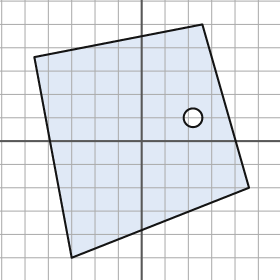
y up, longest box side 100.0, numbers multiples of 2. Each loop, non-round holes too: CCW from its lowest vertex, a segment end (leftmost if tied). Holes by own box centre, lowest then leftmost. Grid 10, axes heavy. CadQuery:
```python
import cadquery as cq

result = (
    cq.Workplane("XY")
    .moveTo(-30.0, -50.0)
    .lineTo(46.0, -20.0)
    .lineTo(26.0, 50.0)
    .lineTo(-46.0, 36.0)
    .close()
    .moveTo(22.0, 10.0)
    .circle(4.0)
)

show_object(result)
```